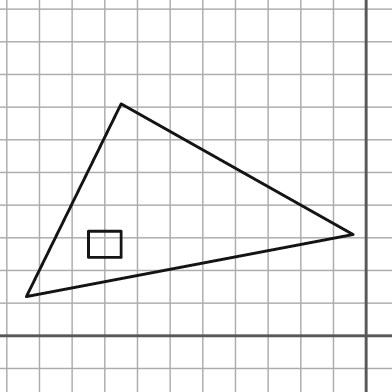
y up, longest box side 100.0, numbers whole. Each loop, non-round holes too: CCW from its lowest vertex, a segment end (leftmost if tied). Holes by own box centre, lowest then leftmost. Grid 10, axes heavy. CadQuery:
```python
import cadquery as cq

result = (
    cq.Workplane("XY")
    .moveTo(-104.0, 12.0)
    .lineTo(-4.0, 31.0)
    .lineTo(-75.0, 71.0)
    .close()
    .moveTo(-85.0, 24.0)
    .lineTo(-75.0, 24.0)
    .lineTo(-75.0, 32.0)
    .lineTo(-85.0, 32.0)
    .close()
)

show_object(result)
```